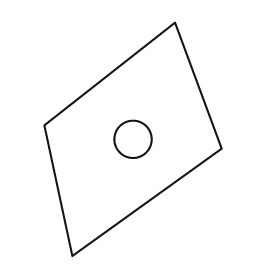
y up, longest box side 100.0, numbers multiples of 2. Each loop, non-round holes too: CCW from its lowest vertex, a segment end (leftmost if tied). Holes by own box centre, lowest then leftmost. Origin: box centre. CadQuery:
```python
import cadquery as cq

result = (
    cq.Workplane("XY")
    .moveTo(-26.0, -50.0)
    .lineTo(38.0, -4.0)
    .lineTo(18.0, 50.0)
    .lineTo(-38.0, 6.0)
    .close()
    .moveTo(0.0, 0.0)
    .circle(8.0)
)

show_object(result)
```